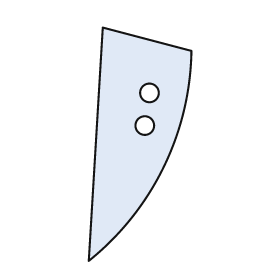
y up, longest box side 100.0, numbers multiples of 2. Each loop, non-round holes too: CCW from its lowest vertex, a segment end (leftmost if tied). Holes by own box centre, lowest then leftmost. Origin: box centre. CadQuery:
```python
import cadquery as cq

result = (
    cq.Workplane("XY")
    .moveTo(-22.0, -50.0)
    .threePointArc((10.0, -10.0), (22.0, 40.0))
    .lineTo(-16.0, 50.0)
    .close()
    .moveTo(2.0, 8.0)
    .circle(4.0)
    .moveTo(4.0, 22.0)
    .circle(4.0)
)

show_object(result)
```